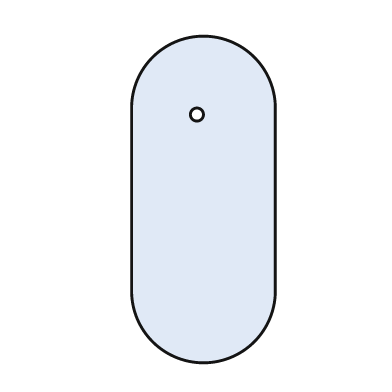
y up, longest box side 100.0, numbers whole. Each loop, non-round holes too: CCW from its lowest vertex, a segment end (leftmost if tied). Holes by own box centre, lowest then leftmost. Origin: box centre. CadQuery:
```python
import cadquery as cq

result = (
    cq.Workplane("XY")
    .moveTo(-22.0, -28.0)
    .threePointArc((0.0, -50.0), (22.0, -28.0))
    .lineTo(22.0, 28.0)
    .threePointArc((0.0, 50.0), (-22.0, 28.0))
    .close()
    .moveTo(-2.0, 26.0)
    .circle(2.0)
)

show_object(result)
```